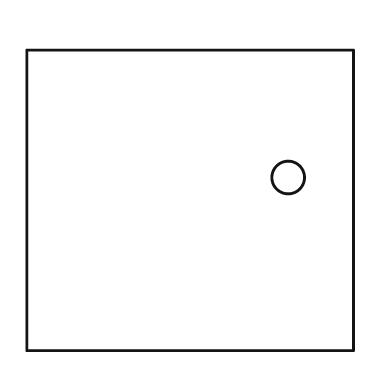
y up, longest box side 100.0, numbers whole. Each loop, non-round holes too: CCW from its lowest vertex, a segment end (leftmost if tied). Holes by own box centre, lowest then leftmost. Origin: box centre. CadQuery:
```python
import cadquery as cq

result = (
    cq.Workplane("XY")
    .moveTo(-50.0, -46.0)
    .lineTo(50.0, -46.0)
    .lineTo(50.0, 46.0)
    .lineTo(-50.0, 46.0)
    .close()
    .moveTo(30.0, 7.0)
    .circle(5.0)
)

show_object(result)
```